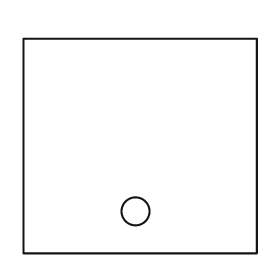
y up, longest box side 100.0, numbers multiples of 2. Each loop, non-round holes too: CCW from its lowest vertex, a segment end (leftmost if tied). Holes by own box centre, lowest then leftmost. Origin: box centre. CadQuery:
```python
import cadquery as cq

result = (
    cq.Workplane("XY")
    .moveTo(-50.0, -46.0)
    .lineTo(50.0, -46.0)
    .lineTo(50.0, 46.0)
    .lineTo(-50.0, 46.0)
    .close()
    .moveTo(-2.0, -28.0)
    .circle(6.0)
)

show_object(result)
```